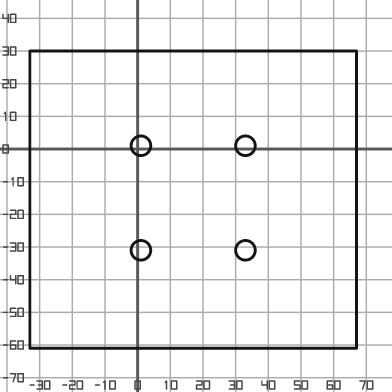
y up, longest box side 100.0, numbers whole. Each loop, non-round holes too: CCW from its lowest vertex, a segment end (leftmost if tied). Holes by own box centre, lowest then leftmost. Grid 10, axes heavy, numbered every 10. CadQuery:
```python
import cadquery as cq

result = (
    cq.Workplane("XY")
    .moveTo(-33.0, -61.0)
    .lineTo(67.0, -61.0)
    .lineTo(67.0, 30.0)
    .lineTo(-33.0, 30.0)
    .close()
    .moveTo(1.0, -31.0)
    .circle(3.0)
    .moveTo(33.0, -31.0)
    .circle(3.0)
    .moveTo(1.0, 1.0)
    .circle(3.0)
    .moveTo(33.0, 1.0)
    .circle(3.0)
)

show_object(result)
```